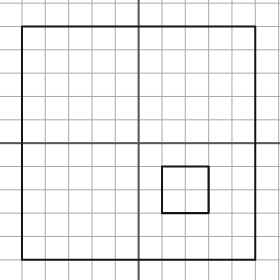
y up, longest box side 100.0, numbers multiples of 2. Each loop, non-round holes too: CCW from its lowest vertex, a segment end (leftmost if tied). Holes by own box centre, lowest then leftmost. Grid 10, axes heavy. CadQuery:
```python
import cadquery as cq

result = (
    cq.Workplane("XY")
    .moveTo(-50.0, -50.0)
    .lineTo(50.0, -50.0)
    .lineTo(50.0, 50.0)
    .lineTo(-50.0, 50.0)
    .close()
    .moveTo(10.0, -30.0)
    .lineTo(30.0, -30.0)
    .lineTo(30.0, -10.0)
    .lineTo(10.0, -10.0)
    .close()
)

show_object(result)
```